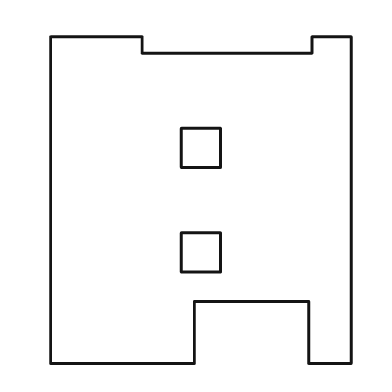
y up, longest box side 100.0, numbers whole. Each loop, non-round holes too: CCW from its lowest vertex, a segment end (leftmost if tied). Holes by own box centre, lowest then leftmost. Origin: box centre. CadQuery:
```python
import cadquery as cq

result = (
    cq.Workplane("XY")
    .moveTo(-46.0, -50.0)
    .lineTo(-2.0, -50.0)
    .lineTo(-2.0, -31.0)
    .lineTo(33.0, -31.0)
    .lineTo(33.0, -50.0)
    .lineTo(46.0, -50.0)
    .lineTo(46.0, 50.0)
    .lineTo(34.0, 50.0)
    .lineTo(34.0, 45.0)
    .lineTo(-18.0, 45.0)
    .lineTo(-18.0, 50.0)
    .lineTo(-46.0, 50.0)
    .close()
    .moveTo(-6.0, -22.0)
    .lineTo(6.0, -22.0)
    .lineTo(6.0, -10.0)
    .lineTo(-6.0, -10.0)
    .close()
    .moveTo(-6.0, 10.0)
    .lineTo(6.0, 10.0)
    .lineTo(6.0, 22.0)
    .lineTo(-6.0, 22.0)
    .close()
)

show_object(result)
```